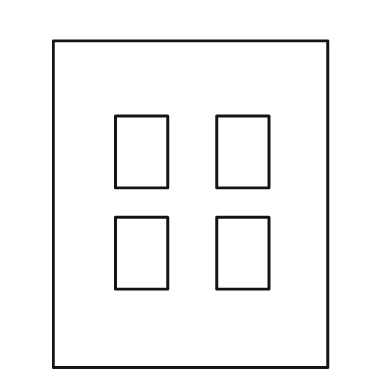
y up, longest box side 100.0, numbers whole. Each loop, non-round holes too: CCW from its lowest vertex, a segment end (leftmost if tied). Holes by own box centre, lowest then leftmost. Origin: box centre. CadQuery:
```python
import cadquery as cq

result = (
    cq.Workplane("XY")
    .moveTo(-42.0, -50.0)
    .lineTo(42.0, -50.0)
    .lineTo(42.0, 50.0)
    .lineTo(-42.0, 50.0)
    .close()
    .moveTo(-23.0, -26.0)
    .lineTo(-7.0, -26.0)
    .lineTo(-7.0, -4.0)
    .lineTo(-23.0, -4.0)
    .close()
    .moveTo(8.0, -26.0)
    .lineTo(24.0, -26.0)
    .lineTo(24.0, -4.0)
    .lineTo(8.0, -4.0)
    .close()
    .moveTo(-23.0, 5.0)
    .lineTo(-7.0, 5.0)
    .lineTo(-7.0, 27.0)
    .lineTo(-23.0, 27.0)
    .close()
    .moveTo(8.0, 5.0)
    .lineTo(24.0, 5.0)
    .lineTo(24.0, 27.0)
    .lineTo(8.0, 27.0)
    .close()
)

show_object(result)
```